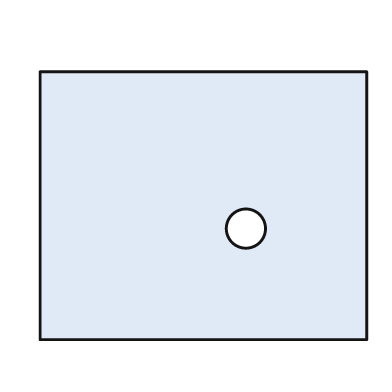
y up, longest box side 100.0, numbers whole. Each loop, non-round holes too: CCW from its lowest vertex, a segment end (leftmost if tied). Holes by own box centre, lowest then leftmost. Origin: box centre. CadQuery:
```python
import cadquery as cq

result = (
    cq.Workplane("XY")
    .moveTo(-50.0, -41.0)
    .lineTo(50.0, -41.0)
    .lineTo(50.0, 41.0)
    .lineTo(-50.0, 41.0)
    .close()
    .moveTo(13.0, -7.0)
    .circle(6.0)
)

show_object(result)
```